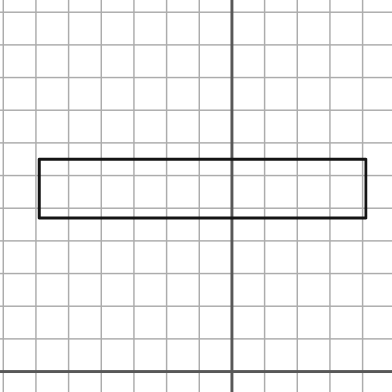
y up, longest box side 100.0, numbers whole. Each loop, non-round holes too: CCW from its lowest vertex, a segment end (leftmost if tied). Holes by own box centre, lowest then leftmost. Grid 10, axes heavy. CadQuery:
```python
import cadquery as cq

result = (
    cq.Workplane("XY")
    .moveTo(-59.0, 47.0)
    .lineTo(41.0, 47.0)
    .lineTo(41.0, 65.0)
    .lineTo(-59.0, 65.0)
    .close()
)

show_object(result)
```